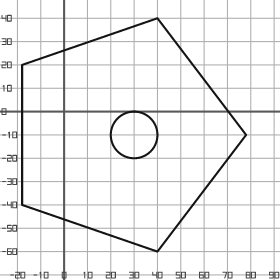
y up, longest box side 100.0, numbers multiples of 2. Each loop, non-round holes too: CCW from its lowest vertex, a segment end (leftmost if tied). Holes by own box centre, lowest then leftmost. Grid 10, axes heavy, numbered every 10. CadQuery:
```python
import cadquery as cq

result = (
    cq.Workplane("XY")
    .moveTo(40.0, -60.0)
    .lineTo(78.0, -10.0)
    .lineTo(40.0, 40.0)
    .lineTo(-18.0, 20.0)
    .lineTo(-18.0, -40.0)
    .close()
    .moveTo(30.0, -10.0)
    .circle(10.0)
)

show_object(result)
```